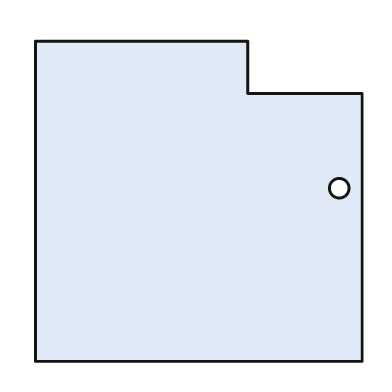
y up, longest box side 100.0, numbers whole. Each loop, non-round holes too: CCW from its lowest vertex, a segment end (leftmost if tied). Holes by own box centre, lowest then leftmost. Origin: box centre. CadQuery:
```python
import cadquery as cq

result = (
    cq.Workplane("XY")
    .moveTo(-50.0, -49.0)
    .lineTo(50.0, -49.0)
    .lineTo(50.0, 33.0)
    .lineTo(15.0, 33.0)
    .lineTo(15.0, 49.0)
    .lineTo(-50.0, 49.0)
    .close()
    .moveTo(43.0, 4.0)
    .circle(3.0)
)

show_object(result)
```